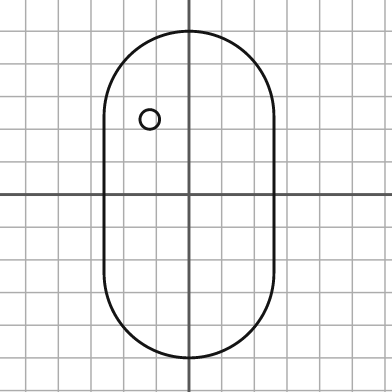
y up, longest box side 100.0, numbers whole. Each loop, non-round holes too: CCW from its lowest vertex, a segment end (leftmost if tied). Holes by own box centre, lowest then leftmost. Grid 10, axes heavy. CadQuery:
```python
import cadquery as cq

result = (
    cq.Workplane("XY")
    .moveTo(-26.0, -24.0)
    .threePointArc((0.0, -50.0), (26.0, -24.0))
    .lineTo(26.0, 24.0)
    .threePointArc((0.0, 50.0), (-26.0, 24.0))
    .close()
    .moveTo(-12.0, 23.0)
    .circle(3.0)
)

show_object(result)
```